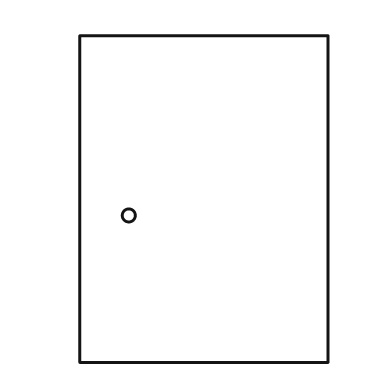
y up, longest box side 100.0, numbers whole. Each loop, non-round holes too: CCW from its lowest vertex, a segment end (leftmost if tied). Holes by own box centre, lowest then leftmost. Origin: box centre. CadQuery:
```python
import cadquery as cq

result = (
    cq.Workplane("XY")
    .moveTo(-38.0, -50.0)
    .lineTo(38.0, -50.0)
    .lineTo(38.0, 50.0)
    .lineTo(-38.0, 50.0)
    .close()
    .moveTo(-23.0, -5.0)
    .circle(2.0)
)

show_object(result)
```